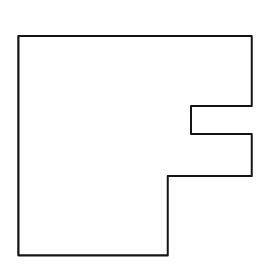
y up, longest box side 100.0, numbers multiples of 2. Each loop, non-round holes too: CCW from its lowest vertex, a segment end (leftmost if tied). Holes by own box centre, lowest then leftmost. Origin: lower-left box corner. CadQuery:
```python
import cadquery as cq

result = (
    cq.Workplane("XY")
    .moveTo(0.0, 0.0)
    .lineTo(64.0, 0.0)
    .lineTo(64.0, 34.0)
    .lineTo(100.0, 34.0)
    .lineTo(100.0, 52.0)
    .lineTo(74.0, 52.0)
    .lineTo(74.0, 64.0)
    .lineTo(100.0, 64.0)
    .lineTo(100.0, 94.0)
    .lineTo(0.0, 94.0)
    .close()
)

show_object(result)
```